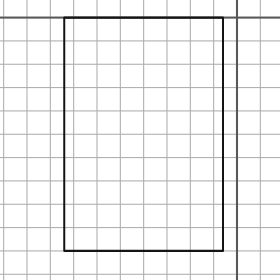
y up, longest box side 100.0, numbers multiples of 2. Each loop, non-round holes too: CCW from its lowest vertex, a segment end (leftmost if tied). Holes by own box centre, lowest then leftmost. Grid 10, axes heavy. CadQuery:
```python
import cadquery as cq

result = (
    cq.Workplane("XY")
    .moveTo(-74.0, -100.0)
    .lineTo(-6.0, -100.0)
    .lineTo(-6.0, 0.0)
    .lineTo(-74.0, 0.0)
    .close()
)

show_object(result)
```